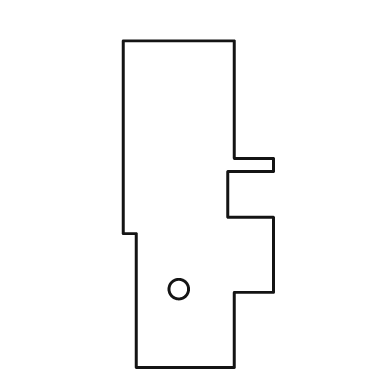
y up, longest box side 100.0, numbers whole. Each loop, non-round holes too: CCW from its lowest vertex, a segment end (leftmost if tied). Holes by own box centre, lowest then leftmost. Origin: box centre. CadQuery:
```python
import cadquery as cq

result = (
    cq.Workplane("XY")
    .moveTo(-19.0, -50.0)
    .lineTo(11.0, -50.0)
    .lineTo(11.0, -27.0)
    .lineTo(23.0, -27.0)
    .lineTo(23.0, -4.0)
    .lineTo(9.0, -4.0)
    .lineTo(9.0, 10.0)
    .lineTo(23.0, 10.0)
    .lineTo(23.0, 14.0)
    .lineTo(11.0, 14.0)
    .lineTo(11.0, 50.0)
    .lineTo(-23.0, 50.0)
    .lineTo(-23.0, -9.0)
    .lineTo(-19.0, -9.0)
    .close()
    .moveTo(-6.0, -26.0)
    .circle(3.0)
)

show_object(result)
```